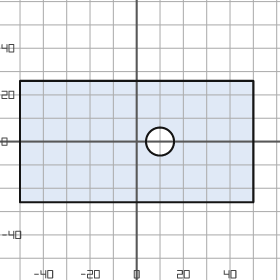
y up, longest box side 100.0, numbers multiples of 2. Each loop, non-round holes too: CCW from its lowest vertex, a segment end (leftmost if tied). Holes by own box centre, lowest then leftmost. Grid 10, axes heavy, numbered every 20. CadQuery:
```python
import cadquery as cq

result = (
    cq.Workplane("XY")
    .moveTo(-50.0, -26.0)
    .lineTo(50.0, -26.0)
    .lineTo(50.0, 26.0)
    .lineTo(-50.0, 26.0)
    .close()
    .moveTo(10.0, 0.0)
    .circle(6.0)
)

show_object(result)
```